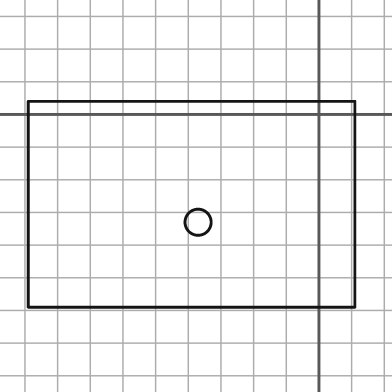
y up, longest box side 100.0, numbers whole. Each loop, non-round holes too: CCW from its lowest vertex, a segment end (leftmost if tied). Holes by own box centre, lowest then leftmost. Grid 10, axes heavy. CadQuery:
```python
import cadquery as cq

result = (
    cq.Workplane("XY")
    .moveTo(-89.0, -59.0)
    .lineTo(11.0, -59.0)
    .lineTo(11.0, 4.0)
    .lineTo(-89.0, 4.0)
    .close()
    .moveTo(-37.0, -33.0)
    .circle(4.0)
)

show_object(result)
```